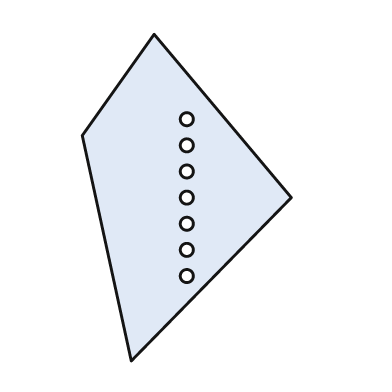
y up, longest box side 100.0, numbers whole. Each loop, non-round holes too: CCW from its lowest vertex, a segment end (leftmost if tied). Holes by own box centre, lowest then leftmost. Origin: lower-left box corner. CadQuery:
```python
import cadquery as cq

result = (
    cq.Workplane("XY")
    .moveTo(15.0, 0.0)
    .lineTo(64.0, 50.0)
    .lineTo(22.0, 100.0)
    .lineTo(0.0, 69.0)
    .close()
    .moveTo(32.0, 26.0)
    .circle(2.0)
    .moveTo(32.0, 34.0)
    .circle(2.0)
    .moveTo(32.0, 42.0)
    .circle(2.0)
    .moveTo(32.0, 50.0)
    .circle(2.0)
    .moveTo(32.0, 58.0)
    .circle(2.0)
    .moveTo(32.0, 66.0)
    .circle(2.0)
    .moveTo(32.0, 74.0)
    .circle(2.0)
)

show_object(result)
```